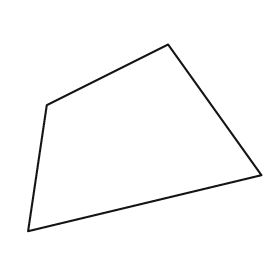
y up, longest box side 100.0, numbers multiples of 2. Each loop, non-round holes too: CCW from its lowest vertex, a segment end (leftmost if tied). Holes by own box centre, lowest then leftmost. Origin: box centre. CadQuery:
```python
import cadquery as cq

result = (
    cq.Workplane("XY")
    .moveTo(-50.0, -40.0)
    .lineTo(50.0, -16.0)
    .lineTo(10.0, 40.0)
    .lineTo(-42.0, 14.0)
    .close()
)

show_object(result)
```